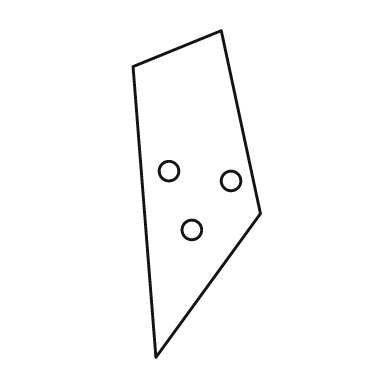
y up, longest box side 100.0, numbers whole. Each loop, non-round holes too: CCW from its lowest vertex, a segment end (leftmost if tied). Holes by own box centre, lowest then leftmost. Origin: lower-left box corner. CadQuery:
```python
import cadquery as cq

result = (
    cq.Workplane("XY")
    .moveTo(7.0, 0.0)
    .lineTo(39.0, 44.0)
    .lineTo(27.0, 100.0)
    .lineTo(0.0, 89.0)
    .close()
    .moveTo(18.0, 39.0)
    .circle(3.0)
    .moveTo(30.0, 54.0)
    .circle(3.0)
    .moveTo(11.0, 57.0)
    .circle(3.0)
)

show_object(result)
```